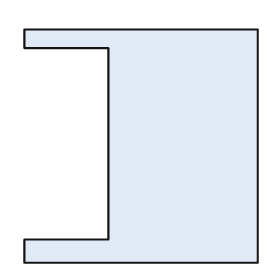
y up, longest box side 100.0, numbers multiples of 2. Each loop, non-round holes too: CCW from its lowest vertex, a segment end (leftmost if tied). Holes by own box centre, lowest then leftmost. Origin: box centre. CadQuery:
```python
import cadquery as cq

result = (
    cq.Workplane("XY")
    .moveTo(-50.0, -50.0)
    .lineTo(50.0, -50.0)
    .lineTo(50.0, 50.0)
    .lineTo(-50.0, 50.0)
    .lineTo(-50.0, 42.0)
    .lineTo(-14.0, 42.0)
    .lineTo(-14.0, -40.0)
    .lineTo(-50.0, -40.0)
    .close()
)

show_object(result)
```